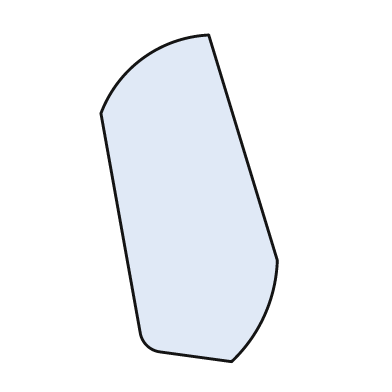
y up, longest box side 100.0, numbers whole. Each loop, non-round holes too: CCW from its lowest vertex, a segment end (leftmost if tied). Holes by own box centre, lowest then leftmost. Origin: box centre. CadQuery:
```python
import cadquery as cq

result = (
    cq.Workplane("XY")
    .moveTo(13.0, -50.0)
    .threePointArc((23.0, -36.0), (27.0, -19.0))
    .lineTo(6.0, 50.0)
    .threePointArc((-14.0, 43.0), (-27.0, 26.0))
    .lineTo(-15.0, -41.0)
    .threePointArc((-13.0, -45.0), (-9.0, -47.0))
    .close()
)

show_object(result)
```